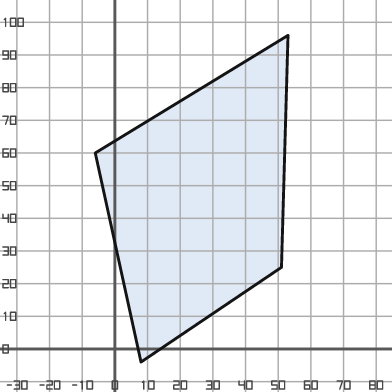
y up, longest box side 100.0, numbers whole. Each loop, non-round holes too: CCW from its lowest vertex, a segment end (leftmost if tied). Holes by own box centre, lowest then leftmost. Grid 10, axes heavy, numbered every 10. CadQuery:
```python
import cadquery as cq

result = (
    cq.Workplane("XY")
    .moveTo(8.0, -4.0)
    .lineTo(51.0, 25.0)
    .lineTo(53.0, 96.0)
    .lineTo(-6.0, 60.0)
    .close()
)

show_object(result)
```